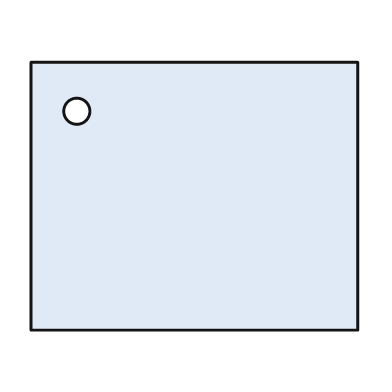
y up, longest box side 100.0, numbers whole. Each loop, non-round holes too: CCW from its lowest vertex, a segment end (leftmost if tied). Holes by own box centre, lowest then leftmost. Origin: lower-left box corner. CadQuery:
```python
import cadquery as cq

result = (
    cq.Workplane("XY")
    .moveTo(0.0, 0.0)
    .lineTo(100.0, 0.0)
    .lineTo(100.0, 82.0)
    .lineTo(0.0, 82.0)
    .close()
    .moveTo(14.0, 67.0)
    .circle(4.0)
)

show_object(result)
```